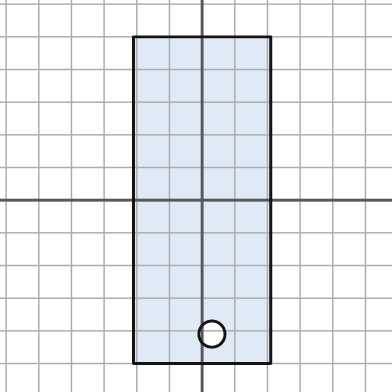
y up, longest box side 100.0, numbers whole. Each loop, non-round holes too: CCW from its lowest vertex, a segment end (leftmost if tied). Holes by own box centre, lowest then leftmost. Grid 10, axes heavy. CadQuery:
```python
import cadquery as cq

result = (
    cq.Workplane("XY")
    .moveTo(-21.0, -50.0)
    .lineTo(21.0, -50.0)
    .lineTo(21.0, 50.0)
    .lineTo(-21.0, 50.0)
    .close()
    .moveTo(3.0, -41.0)
    .circle(4.0)
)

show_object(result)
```